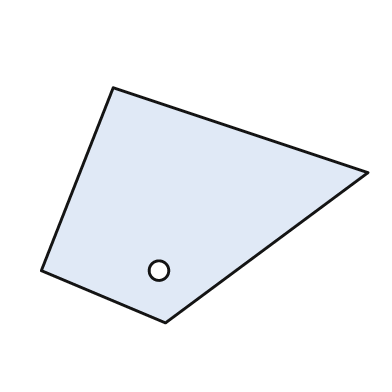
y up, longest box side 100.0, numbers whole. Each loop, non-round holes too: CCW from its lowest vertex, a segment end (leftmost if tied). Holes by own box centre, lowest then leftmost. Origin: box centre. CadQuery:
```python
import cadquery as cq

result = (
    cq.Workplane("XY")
    .moveTo(-12.0, -36.0)
    .lineTo(50.0, 10.0)
    .lineTo(-28.0, 36.0)
    .lineTo(-50.0, -20.0)
    .close()
    .moveTo(-14.0, -20.0)
    .circle(3.0)
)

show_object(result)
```